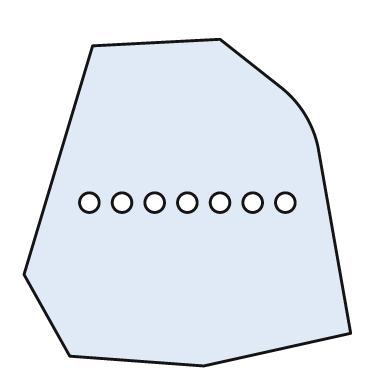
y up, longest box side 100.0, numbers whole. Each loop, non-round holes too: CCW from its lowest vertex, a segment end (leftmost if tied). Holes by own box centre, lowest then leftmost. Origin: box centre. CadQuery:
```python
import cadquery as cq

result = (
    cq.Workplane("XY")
    .moveTo(5.0, -50.0)
    .lineTo(50.0, -40.0)
    .lineTo(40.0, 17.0)
    .threePointArc((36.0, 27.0), (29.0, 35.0))
    .lineTo(10.0, 50.0)
    .lineTo(-29.0, 48.0)
    .lineTo(-50.0, -22.0)
    .lineTo(-36.0, -47.0)
    .close()
    .moveTo(-30.0, 0.0)
    .circle(3.0)
    .moveTo(-20.0, 0.0)
    .circle(3.0)
    .moveTo(-10.0, 0.0)
    .circle(3.0)
    .moveTo(0.0, 0.0)
    .circle(3.0)
    .moveTo(10.0, 0.0)
    .circle(3.0)
    .moveTo(20.0, 0.0)
    .circle(3.0)
    .moveTo(30.0, 0.0)
    .circle(3.0)
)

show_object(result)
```